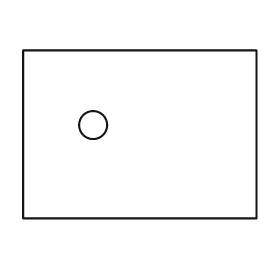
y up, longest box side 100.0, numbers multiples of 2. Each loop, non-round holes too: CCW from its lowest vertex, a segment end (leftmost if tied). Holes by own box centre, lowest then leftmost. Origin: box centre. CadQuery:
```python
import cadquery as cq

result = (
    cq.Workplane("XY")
    .moveTo(-50.0, -36.0)
    .lineTo(50.0, -36.0)
    .lineTo(50.0, 36.0)
    .lineTo(-50.0, 36.0)
    .close()
    .moveTo(-20.0, 4.0)
    .circle(6.0)
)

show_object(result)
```